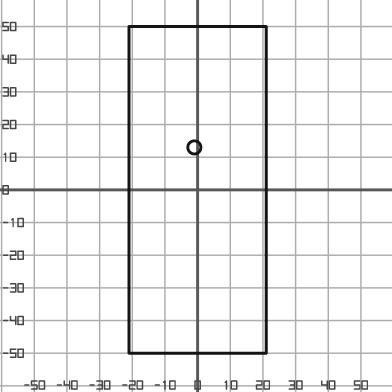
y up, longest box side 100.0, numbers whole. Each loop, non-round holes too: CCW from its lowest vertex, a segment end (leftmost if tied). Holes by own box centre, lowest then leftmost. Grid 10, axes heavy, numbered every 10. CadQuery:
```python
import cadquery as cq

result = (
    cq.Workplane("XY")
    .moveTo(-21.0, -50.0)
    .lineTo(21.0, -50.0)
    .lineTo(21.0, 50.0)
    .lineTo(-21.0, 50.0)
    .close()
    .moveTo(-1.0, 13.0)
    .circle(2.0)
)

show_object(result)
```